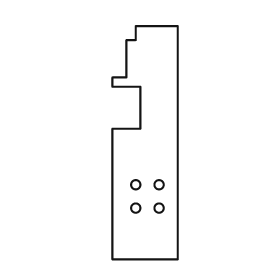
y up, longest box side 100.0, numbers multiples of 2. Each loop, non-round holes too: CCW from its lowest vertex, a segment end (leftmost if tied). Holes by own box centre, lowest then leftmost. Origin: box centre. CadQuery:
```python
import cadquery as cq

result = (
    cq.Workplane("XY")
    .moveTo(-14.0, -50.0)
    .lineTo(14.0, -50.0)
    .lineTo(14.0, 50.0)
    .lineTo(-4.0, 50.0)
    .lineTo(-4.0, 44.0)
    .lineTo(-8.0, 44.0)
    .lineTo(-8.0, 28.0)
    .lineTo(-14.0, 28.0)
    .lineTo(-14.0, 24.0)
    .lineTo(-2.0, 24.0)
    .lineTo(-2.0, 6.0)
    .lineTo(-14.0, 6.0)
    .close()
    .moveTo(-4.0, -28.0)
    .circle(2.0)
    .moveTo(6.0, -28.0)
    .circle(2.0)
    .moveTo(-4.0, -18.0)
    .circle(2.0)
    .moveTo(6.0, -18.0)
    .circle(2.0)
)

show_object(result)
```